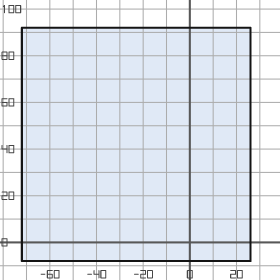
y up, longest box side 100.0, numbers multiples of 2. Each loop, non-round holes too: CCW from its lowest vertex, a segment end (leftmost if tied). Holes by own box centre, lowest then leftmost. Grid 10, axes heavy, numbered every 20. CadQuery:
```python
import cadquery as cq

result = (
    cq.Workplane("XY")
    .moveTo(-72.0, -8.0)
    .lineTo(26.0, -8.0)
    .lineTo(26.0, 92.0)
    .lineTo(-72.0, 92.0)
    .close()
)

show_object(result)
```